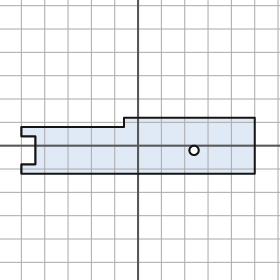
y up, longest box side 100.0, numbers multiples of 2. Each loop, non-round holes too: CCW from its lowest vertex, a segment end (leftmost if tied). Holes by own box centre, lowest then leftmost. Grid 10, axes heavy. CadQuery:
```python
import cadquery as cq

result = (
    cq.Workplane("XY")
    .moveTo(-50.0, -12.0)
    .lineTo(50.0, -12.0)
    .lineTo(50.0, 12.0)
    .lineTo(-6.0, 12.0)
    .lineTo(-6.0, 8.0)
    .lineTo(-50.0, 8.0)
    .lineTo(-50.0, 4.0)
    .lineTo(-44.0, 4.0)
    .lineTo(-44.0, -8.0)
    .lineTo(-50.0, -8.0)
    .close()
    .moveTo(24.0, -2.0)
    .circle(2.0)
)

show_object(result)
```